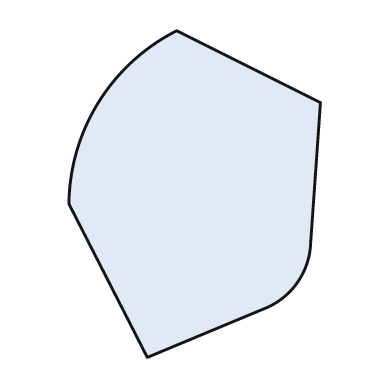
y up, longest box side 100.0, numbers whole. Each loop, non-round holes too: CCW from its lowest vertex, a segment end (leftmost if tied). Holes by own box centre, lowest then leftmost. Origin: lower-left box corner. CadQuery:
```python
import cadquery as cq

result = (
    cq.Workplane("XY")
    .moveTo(24.0, 0.0)
    .lineTo(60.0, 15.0)
    .threePointArc((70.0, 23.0), (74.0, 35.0))
    .lineTo(77.0, 78.0)
    .lineTo(33.0, 100.0)
    .threePointArc((9.0, 78.0), (0.0, 47.0))
    .close()
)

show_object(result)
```